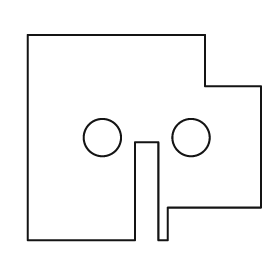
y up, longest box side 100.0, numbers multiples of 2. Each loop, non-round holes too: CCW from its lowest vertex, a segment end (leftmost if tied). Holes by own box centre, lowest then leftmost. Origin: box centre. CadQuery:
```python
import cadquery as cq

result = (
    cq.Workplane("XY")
    .moveTo(-50.0, -44.0)
    .lineTo(-4.0, -44.0)
    .lineTo(-4.0, -2.0)
    .lineTo(6.0, -2.0)
    .lineTo(6.0, -44.0)
    .lineTo(10.0, -44.0)
    .lineTo(10.0, -30.0)
    .lineTo(50.0, -30.0)
    .lineTo(50.0, 22.0)
    .lineTo(26.0, 22.0)
    .lineTo(26.0, 44.0)
    .lineTo(-50.0, 44.0)
    .close()
    .moveTo(-18.0, 0.0)
    .circle(8.0)
    .moveTo(20.0, 0.0)
    .circle(8.0)
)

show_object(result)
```